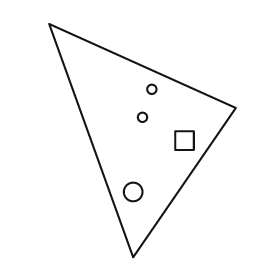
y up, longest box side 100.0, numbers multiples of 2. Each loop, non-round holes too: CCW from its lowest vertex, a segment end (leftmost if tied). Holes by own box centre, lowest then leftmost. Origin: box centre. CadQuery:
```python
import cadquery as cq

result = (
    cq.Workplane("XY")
    .moveTo(-4.0, -50.0)
    .lineTo(40.0, 14.0)
    .lineTo(-40.0, 50.0)
    .close()
    .moveTo(-4.0, -22.0)
    .circle(4.0)
    .moveTo(14.0, -4.0)
    .lineTo(22.0, -4.0)
    .lineTo(22.0, 4.0)
    .lineTo(14.0, 4.0)
    .close()
    .moveTo(0.0, 10.0)
    .circle(2.0)
    .moveTo(4.0, 22.0)
    .circle(2.0)
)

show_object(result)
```